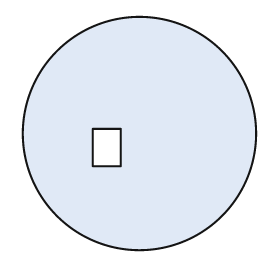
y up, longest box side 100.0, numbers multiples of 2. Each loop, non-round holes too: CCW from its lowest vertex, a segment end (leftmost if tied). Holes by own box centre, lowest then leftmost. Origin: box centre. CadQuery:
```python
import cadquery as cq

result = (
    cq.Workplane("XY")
    .moveTo(0.0, 0.0)
    .circle(50.0)
    .moveTo(-20.0, -14.0)
    .lineTo(-8.0, -14.0)
    .lineTo(-8.0, 2.0)
    .lineTo(-20.0, 2.0)
    .close()
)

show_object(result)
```